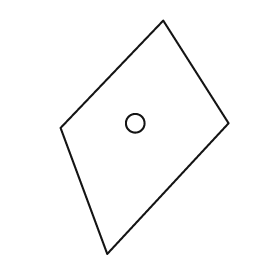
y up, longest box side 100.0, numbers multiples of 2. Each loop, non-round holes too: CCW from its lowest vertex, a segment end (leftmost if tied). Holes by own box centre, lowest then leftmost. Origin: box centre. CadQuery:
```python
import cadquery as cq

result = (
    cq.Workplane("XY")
    .moveTo(-16.0, -50.0)
    .lineTo(36.0, 6.0)
    .lineTo(8.0, 50.0)
    .lineTo(-36.0, 4.0)
    .close()
    .moveTo(-4.0, 6.0)
    .circle(4.0)
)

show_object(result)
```